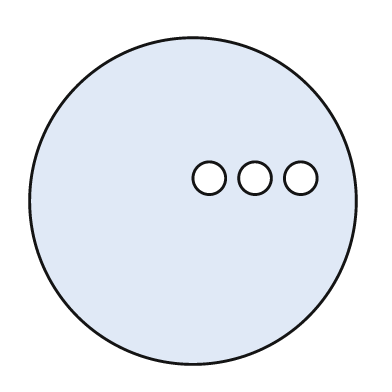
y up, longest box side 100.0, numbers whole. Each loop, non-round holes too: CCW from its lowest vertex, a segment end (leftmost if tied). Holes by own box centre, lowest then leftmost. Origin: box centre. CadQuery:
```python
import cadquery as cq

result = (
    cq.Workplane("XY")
    .moveTo(0.0, 0.0)
    .circle(50.0)
    .moveTo(5.0, 7.0)
    .circle(5.0)
    .moveTo(19.0, 7.0)
    .circle(5.0)
    .moveTo(33.0, 7.0)
    .circle(5.0)
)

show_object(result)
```